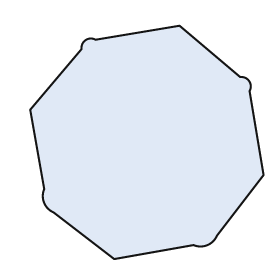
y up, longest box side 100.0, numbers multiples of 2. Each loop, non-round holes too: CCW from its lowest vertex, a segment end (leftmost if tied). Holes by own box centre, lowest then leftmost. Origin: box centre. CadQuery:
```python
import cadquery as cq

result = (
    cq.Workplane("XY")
    .moveTo(-14.0, -50.0)
    .lineTo(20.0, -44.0)
    .threePointArc((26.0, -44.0), (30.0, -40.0))
    .lineTo(50.0, -14.0)
    .lineTo(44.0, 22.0)
    .threePointArc((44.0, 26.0), (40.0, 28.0))
    .lineTo(14.0, 50.0)
    .lineTo(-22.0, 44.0)
    .threePointArc((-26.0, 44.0), (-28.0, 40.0))
    .lineTo(-50.0, 14.0)
    .lineTo(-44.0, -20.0)
    .threePointArc((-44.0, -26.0), (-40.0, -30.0))
    .close()
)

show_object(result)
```